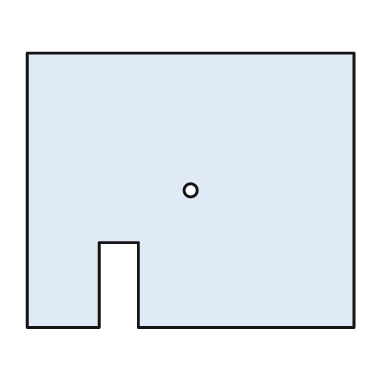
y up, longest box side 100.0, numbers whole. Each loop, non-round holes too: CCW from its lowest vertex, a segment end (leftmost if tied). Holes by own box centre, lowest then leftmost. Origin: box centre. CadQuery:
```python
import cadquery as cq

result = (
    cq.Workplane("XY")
    .moveTo(-50.0, -42.0)
    .lineTo(-28.0, -42.0)
    .lineTo(-28.0, -16.0)
    .lineTo(-16.0, -16.0)
    .lineTo(-16.0, -42.0)
    .lineTo(50.0, -42.0)
    .lineTo(50.0, 42.0)
    .lineTo(-50.0, 42.0)
    .close()
    .moveTo(0.0, 0.0)
    .circle(2.0)
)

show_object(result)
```